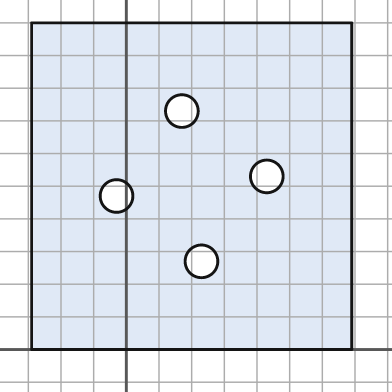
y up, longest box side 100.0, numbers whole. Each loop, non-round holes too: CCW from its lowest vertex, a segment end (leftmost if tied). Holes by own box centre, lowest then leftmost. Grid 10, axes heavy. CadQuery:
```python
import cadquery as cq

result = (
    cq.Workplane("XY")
    .moveTo(-29.0, 0.0)
    .lineTo(69.0, 0.0)
    .lineTo(69.0, 100.0)
    .lineTo(-29.0, 100.0)
    .close()
    .moveTo(23.0, 27.0)
    .circle(5.0)
    .moveTo(-3.0, 47.0)
    .circle(5.0)
    .moveTo(43.0, 53.0)
    .circle(5.0)
    .moveTo(17.0, 73.0)
    .circle(5.0)
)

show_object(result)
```